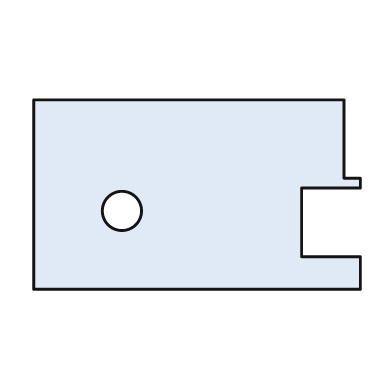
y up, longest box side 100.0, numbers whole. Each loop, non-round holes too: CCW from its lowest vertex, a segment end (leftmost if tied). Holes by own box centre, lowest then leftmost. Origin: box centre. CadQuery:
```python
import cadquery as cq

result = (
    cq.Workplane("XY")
    .moveTo(-50.0, -29.0)
    .lineTo(50.0, -29.0)
    .lineTo(50.0, -19.0)
    .lineTo(32.0, -19.0)
    .lineTo(32.0, 2.0)
    .lineTo(50.0, 2.0)
    .lineTo(50.0, 5.0)
    .lineTo(45.0, 5.0)
    .lineTo(45.0, 29.0)
    .lineTo(-50.0, 29.0)
    .close()
    .moveTo(-23.0, -5.0)
    .circle(6.0)
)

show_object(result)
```